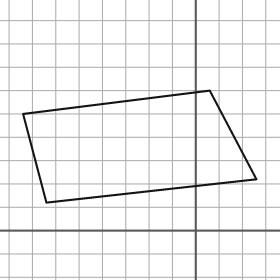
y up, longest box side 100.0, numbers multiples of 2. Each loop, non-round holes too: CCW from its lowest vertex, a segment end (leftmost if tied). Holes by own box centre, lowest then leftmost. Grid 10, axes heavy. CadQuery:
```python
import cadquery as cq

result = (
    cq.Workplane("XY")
    .moveTo(-64.0, 12.0)
    .lineTo(26.0, 22.0)
    .lineTo(6.0, 60.0)
    .lineTo(-74.0, 50.0)
    .close()
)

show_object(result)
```